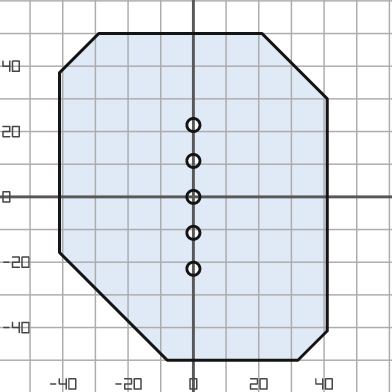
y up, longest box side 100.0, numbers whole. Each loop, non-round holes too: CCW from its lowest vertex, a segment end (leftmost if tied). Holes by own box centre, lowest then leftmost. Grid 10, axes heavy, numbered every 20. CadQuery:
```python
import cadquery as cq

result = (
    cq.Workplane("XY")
    .moveTo(-8.0, -50.0)
    .lineTo(32.0, -50.0)
    .lineTo(41.0, -41.0)
    .lineTo(41.0, 30.0)
    .lineTo(21.0, 50.0)
    .lineTo(-29.0, 50.0)
    .lineTo(-41.0, 38.0)
    .lineTo(-41.0, -17.0)
    .close()
    .moveTo(0.0, -22.0)
    .circle(2.0)
    .moveTo(0.0, -11.0)
    .circle(2.0)
    .moveTo(0.0, 0.0)
    .circle(2.0)
    .moveTo(0.0, 11.0)
    .circle(2.0)
    .moveTo(0.0, 22.0)
    .circle(2.0)
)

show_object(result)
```